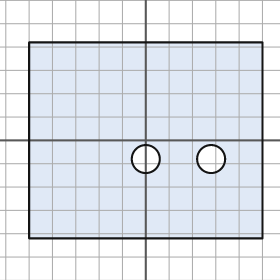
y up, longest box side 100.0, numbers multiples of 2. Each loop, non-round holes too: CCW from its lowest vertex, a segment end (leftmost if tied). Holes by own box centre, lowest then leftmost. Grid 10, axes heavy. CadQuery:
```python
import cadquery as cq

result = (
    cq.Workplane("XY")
    .moveTo(-50.0, -42.0)
    .lineTo(50.0, -42.0)
    .lineTo(50.0, 42.0)
    .lineTo(-50.0, 42.0)
    .close()
    .moveTo(0.0, -8.0)
    .circle(6.0)
    .moveTo(28.0, -8.0)
    .circle(6.0)
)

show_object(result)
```